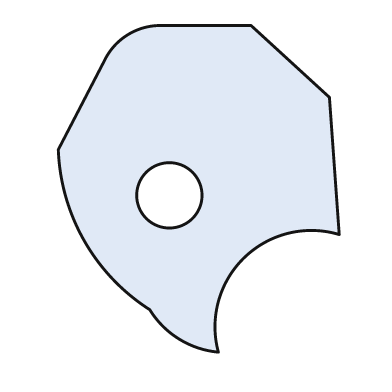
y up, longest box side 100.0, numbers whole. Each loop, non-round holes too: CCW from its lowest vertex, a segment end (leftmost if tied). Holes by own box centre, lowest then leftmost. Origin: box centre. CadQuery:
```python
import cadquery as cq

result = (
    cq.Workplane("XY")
    .moveTo(6.0, -50.0)
    .threePointArc((14.0, -21.0), (43.0, -14.0))
    .lineTo(40.0, 28.0)
    .lineTo(16.0, 50.0)
    .lineTo(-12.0, 50.0)
    .threePointArc((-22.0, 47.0), (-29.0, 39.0))
    .lineTo(-43.0, 12.0)
    .threePointArc((-35.0, -16.0), (-15.0, -37.0))
    .threePointArc((-6.0, -46.0), (6.0, -50.0))
    .close()
    .moveTo(-9.0, -2.0)
    .circle(10.0)
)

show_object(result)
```